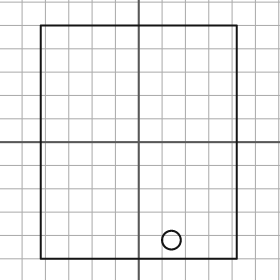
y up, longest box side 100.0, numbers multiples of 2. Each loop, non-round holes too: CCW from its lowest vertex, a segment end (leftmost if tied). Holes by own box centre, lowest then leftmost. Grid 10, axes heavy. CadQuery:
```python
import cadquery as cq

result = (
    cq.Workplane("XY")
    .moveTo(-42.0, -50.0)
    .lineTo(42.0, -50.0)
    .lineTo(42.0, 50.0)
    .lineTo(-42.0, 50.0)
    .close()
    .moveTo(14.0, -42.0)
    .circle(4.0)
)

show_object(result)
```